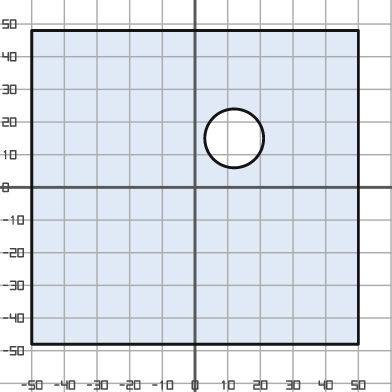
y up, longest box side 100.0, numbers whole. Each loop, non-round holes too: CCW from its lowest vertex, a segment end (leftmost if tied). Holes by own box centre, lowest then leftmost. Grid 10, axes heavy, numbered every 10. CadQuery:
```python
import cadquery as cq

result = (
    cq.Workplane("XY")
    .moveTo(-50.0, -48.0)
    .lineTo(50.0, -48.0)
    .lineTo(50.0, 48.0)
    .lineTo(-50.0, 48.0)
    .close()
    .moveTo(12.0, 15.0)
    .circle(9.0)
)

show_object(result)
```